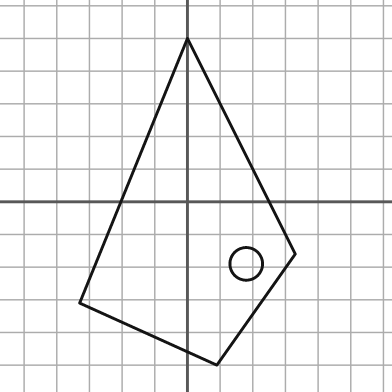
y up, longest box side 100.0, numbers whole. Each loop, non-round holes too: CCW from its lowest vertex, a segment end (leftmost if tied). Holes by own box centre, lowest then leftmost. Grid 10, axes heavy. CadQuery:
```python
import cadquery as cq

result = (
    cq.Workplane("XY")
    .moveTo(9.0, -50.0)
    .lineTo(33.0, -16.0)
    .lineTo(0.0, 50.0)
    .lineTo(-33.0, -31.0)
    .close()
    .moveTo(18.0, -19.0)
    .circle(5.0)
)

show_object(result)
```